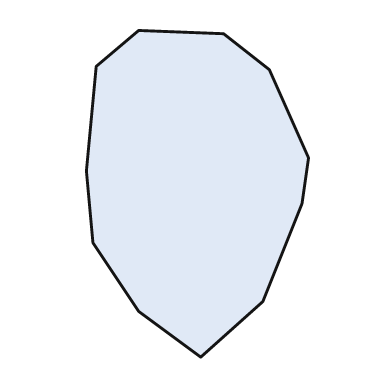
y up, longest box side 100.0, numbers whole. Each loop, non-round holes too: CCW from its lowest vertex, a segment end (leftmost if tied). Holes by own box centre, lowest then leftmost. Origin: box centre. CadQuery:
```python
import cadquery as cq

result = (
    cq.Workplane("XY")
    .moveTo(1.0, -50.0)
    .lineTo(20.0, -33.0)
    .lineTo(32.0, -3.0)
    .lineTo(34.0, 11.0)
    .lineTo(22.0, 38.0)
    .lineTo(8.0, 49.0)
    .lineTo(-18.0, 50.0)
    .lineTo(-31.0, 39.0)
    .lineTo(-34.0, 7.0)
    .lineTo(-32.0, -15.0)
    .lineTo(-18.0, -36.0)
    .close()
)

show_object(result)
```